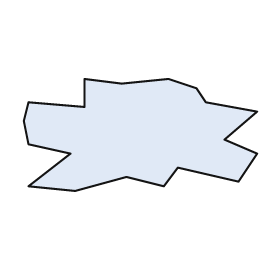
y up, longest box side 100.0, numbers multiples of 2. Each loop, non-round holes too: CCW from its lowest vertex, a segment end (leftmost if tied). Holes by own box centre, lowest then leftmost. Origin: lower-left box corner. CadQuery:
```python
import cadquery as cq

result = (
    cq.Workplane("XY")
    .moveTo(22.0, 0.0)
    .lineTo(44.0, 6.0)
    .lineTo(60.0, 2.0)
    .lineTo(66.0, 10.0)
    .lineTo(92.0, 4.0)
    .lineTo(100.0, 16.0)
    .lineTo(86.0, 22.0)
    .lineTo(100.0, 34.0)
    .lineTo(78.0, 38.0)
    .lineTo(74.0, 44.0)
    .lineTo(62.0, 48.0)
    .lineTo(42.0, 46.0)
    .lineTo(26.0, 48.0)
    .lineTo(26.0, 36.0)
    .lineTo(2.0, 38.0)
    .lineTo(0.0, 30.0)
    .lineTo(2.0, 20.0)
    .lineTo(20.0, 16.0)
    .lineTo(2.0, 2.0)
    .close()
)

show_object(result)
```